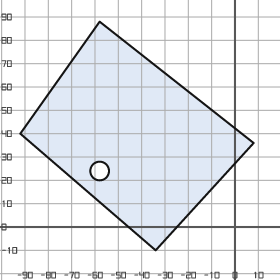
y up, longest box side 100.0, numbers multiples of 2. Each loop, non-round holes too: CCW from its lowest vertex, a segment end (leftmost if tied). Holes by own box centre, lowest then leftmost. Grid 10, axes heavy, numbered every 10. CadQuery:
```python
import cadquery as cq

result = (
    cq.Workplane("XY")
    .moveTo(-34.0, -10.0)
    .lineTo(8.0, 36.0)
    .lineTo(-58.0, 88.0)
    .lineTo(-92.0, 40.0)
    .close()
    .moveTo(-58.0, 24.0)
    .circle(4.0)
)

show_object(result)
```